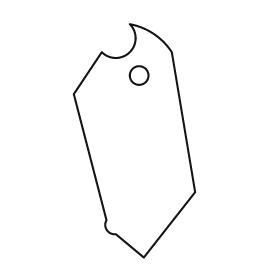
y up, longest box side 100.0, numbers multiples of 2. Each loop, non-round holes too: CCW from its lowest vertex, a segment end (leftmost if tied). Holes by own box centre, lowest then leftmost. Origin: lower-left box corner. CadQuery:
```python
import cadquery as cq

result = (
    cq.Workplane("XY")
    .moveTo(30.0, 0.0)
    .lineTo(52.0, 28.0)
    .lineTo(42.0, 88.0)
    .threePointArc((34.0, 96.0), (24.0, 100.0))
    .threePointArc((24.0, 88.0), (12.0, 88.0))
    .lineTo(0.0, 70.0)
    .lineTo(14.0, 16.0)
    .threePointArc((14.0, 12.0), (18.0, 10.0))
    .close()
    .moveTo(28.0, 78.0)
    .circle(4.0)
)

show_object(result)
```